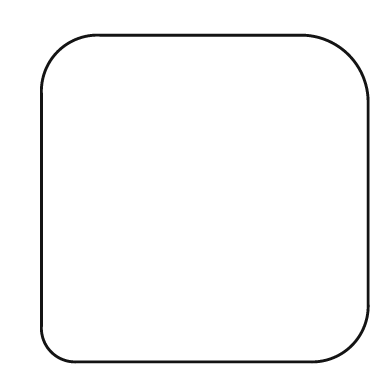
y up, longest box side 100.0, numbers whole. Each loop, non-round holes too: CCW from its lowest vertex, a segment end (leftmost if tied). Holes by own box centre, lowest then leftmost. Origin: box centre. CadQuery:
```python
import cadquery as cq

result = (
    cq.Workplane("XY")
    .moveTo(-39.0, -50.0)
    .lineTo(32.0, -50.0)
    .threePointArc((45.0, -45.0), (50.0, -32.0))
    .lineTo(50.0, 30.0)
    .threePointArc((44.0, 44.0), (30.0, 50.0))
    .lineTo(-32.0, 50.0)
    .threePointArc((-45.0, 45.0), (-50.0, 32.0))
    .lineTo(-50.0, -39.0)
    .threePointArc((-47.0, -47.0), (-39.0, -50.0))
    .close()
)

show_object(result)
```